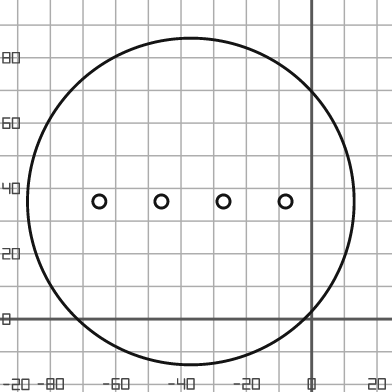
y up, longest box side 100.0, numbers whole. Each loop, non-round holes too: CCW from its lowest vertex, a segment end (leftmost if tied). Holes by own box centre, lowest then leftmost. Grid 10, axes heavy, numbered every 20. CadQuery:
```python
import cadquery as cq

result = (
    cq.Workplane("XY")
    .moveTo(-37.0, 36.0)
    .circle(50.0)
    .moveTo(-65.0, 36.0)
    .circle(2.0)
    .moveTo(-46.0, 36.0)
    .circle(2.0)
    .moveTo(-27.0, 36.0)
    .circle(2.0)
    .moveTo(-8.0, 36.0)
    .circle(2.0)
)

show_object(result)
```